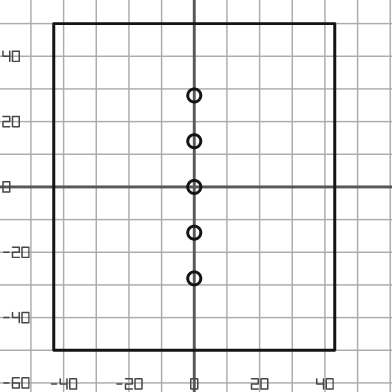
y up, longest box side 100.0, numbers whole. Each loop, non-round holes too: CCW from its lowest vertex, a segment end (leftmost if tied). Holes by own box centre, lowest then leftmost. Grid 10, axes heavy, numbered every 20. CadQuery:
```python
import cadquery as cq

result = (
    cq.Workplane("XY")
    .moveTo(-43.0, -50.0)
    .lineTo(43.0, -50.0)
    .lineTo(43.0, 50.0)
    .lineTo(-43.0, 50.0)
    .close()
    .moveTo(0.0, -28.0)
    .circle(2.0)
    .moveTo(0.0, -14.0)
    .circle(2.0)
    .moveTo(0.0, 0.0)
    .circle(2.0)
    .moveTo(0.0, 14.0)
    .circle(2.0)
    .moveTo(0.0, 28.0)
    .circle(2.0)
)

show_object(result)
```